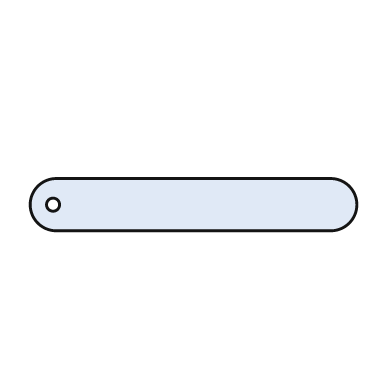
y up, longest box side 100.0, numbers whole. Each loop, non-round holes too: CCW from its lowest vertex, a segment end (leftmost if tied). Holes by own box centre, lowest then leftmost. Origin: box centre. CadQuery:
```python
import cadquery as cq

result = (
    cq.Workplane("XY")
    .moveTo(-42.0, -8.0)
    .lineTo(42.0, -8.0)
    .threePointArc((50.0, 0.0), (42.0, 8.0))
    .lineTo(-42.0, 8.0)
    .threePointArc((-50.0, 0.0), (-42.0, -8.0))
    .close()
    .moveTo(-43.0, 0.0)
    .circle(2.0)
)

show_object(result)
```